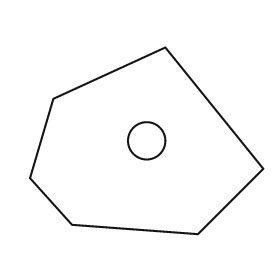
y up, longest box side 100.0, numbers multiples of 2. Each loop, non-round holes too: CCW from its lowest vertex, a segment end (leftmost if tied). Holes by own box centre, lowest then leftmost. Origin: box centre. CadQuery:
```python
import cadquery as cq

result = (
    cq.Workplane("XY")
    .moveTo(22.0, -40.0)
    .lineTo(50.0, -12.0)
    .lineTo(8.0, 40.0)
    .lineTo(-40.0, 18.0)
    .lineTo(-50.0, -16.0)
    .lineTo(-32.0, -36.0)
    .close()
    .moveTo(0.0, 0.0)
    .circle(8.0)
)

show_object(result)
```